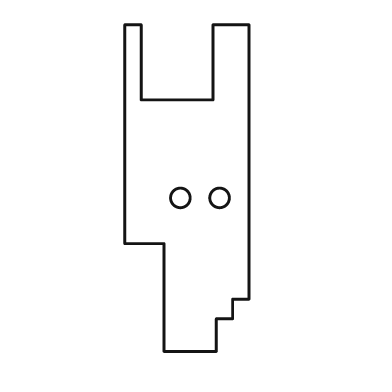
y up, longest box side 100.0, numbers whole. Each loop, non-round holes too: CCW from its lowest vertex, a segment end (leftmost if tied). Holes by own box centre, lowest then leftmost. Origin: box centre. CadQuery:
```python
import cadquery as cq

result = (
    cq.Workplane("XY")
    .moveTo(-7.0, -50.0)
    .lineTo(9.0, -50.0)
    .lineTo(9.0, -40.0)
    .lineTo(14.0, -40.0)
    .lineTo(14.0, -34.0)
    .lineTo(19.0, -34.0)
    .lineTo(19.0, 50.0)
    .lineTo(8.0, 50.0)
    .lineTo(8.0, 27.0)
    .lineTo(-14.0, 27.0)
    .lineTo(-14.0, 50.0)
    .lineTo(-19.0, 50.0)
    .lineTo(-19.0, -17.0)
    .lineTo(-7.0, -17.0)
    .close()
    .moveTo(-2.0, -3.0)
    .circle(3.0)
    .moveTo(10.0, -3.0)
    .circle(3.0)
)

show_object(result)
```